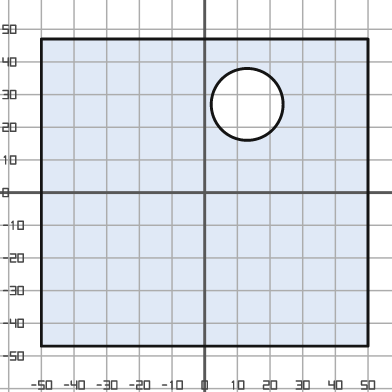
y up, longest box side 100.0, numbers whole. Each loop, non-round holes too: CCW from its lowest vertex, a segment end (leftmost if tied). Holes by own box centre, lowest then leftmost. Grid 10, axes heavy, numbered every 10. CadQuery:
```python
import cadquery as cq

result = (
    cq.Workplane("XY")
    .moveTo(-50.0, -47.0)
    .lineTo(50.0, -47.0)
    .lineTo(50.0, 47.0)
    .lineTo(-50.0, 47.0)
    .close()
    .moveTo(13.0, 27.0)
    .circle(11.0)
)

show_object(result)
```